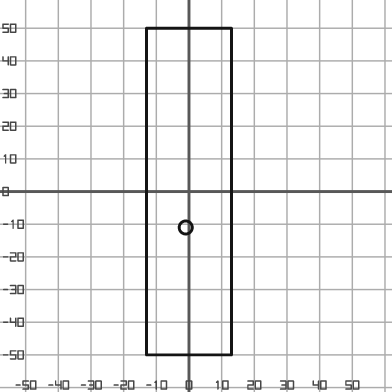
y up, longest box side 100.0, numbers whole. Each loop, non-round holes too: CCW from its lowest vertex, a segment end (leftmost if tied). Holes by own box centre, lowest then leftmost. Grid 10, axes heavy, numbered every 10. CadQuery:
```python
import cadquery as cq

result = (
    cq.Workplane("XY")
    .moveTo(-13.0, -50.0)
    .lineTo(13.0, -50.0)
    .lineTo(13.0, 50.0)
    .lineTo(-13.0, 50.0)
    .close()
    .moveTo(-1.0, -11.0)
    .circle(2.0)
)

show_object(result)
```